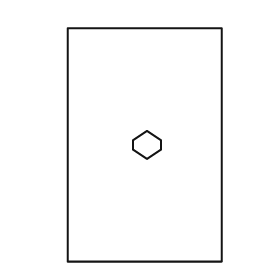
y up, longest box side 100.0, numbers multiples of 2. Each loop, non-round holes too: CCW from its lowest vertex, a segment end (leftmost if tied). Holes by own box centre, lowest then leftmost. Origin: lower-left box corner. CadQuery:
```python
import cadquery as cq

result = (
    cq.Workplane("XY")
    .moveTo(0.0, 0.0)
    .lineTo(66.0, 0.0)
    .lineTo(66.0, 100.0)
    .lineTo(0.0, 100.0)
    .close()
    .moveTo(34.0, 44.0)
    .lineTo(40.0, 48.0)
    .lineTo(40.0, 52.0)
    .lineTo(34.0, 56.0)
    .lineTo(28.0, 52.0)
    .lineTo(28.0, 48.0)
    .close()
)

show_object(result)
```